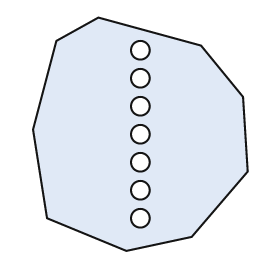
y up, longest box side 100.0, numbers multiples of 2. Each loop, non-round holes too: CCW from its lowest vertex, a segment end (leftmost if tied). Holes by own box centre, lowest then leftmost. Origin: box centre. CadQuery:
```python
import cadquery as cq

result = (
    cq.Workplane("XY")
    .moveTo(-6.0, -50.0)
    .lineTo(22.0, -44.0)
    .lineTo(46.0, -16.0)
    .lineTo(44.0, 16.0)
    .lineTo(26.0, 38.0)
    .lineTo(-18.0, 50.0)
    .lineTo(-36.0, 40.0)
    .lineTo(-46.0, 2.0)
    .lineTo(-40.0, -36.0)
    .close()
    .moveTo(0.0, -36.0)
    .circle(4.0)
    .moveTo(0.0, -24.0)
    .circle(4.0)
    .moveTo(0.0, -12.0)
    .circle(4.0)
    .moveTo(0.0, 0.0)
    .circle(4.0)
    .moveTo(0.0, 12.0)
    .circle(4.0)
    .moveTo(0.0, 24.0)
    .circle(4.0)
    .moveTo(0.0, 36.0)
    .circle(4.0)
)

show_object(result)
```